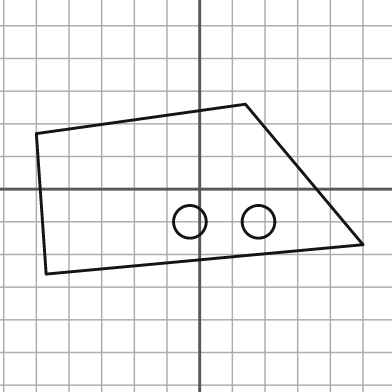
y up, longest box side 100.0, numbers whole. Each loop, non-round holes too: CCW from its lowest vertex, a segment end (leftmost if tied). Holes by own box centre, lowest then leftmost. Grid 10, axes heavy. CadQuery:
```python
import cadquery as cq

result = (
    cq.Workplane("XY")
    .moveTo(-47.0, -26.0)
    .lineTo(50.0, -17.0)
    .lineTo(14.0, 26.0)
    .lineTo(-50.0, 17.0)
    .close()
    .moveTo(-3.0, -10.0)
    .circle(5.0)
    .moveTo(18.0, -10.0)
    .circle(5.0)
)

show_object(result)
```